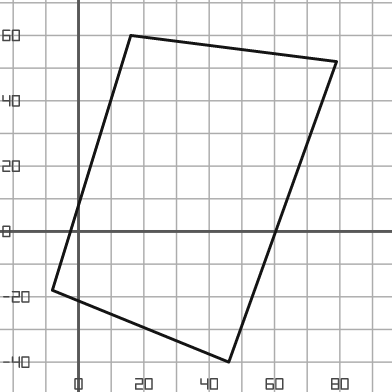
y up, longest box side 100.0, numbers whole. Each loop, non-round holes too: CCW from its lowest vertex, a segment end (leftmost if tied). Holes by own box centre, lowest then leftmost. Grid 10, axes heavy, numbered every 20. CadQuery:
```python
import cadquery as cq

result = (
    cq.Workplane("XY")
    .moveTo(46.0, -40.0)
    .lineTo(79.0, 52.0)
    .lineTo(16.0, 60.0)
    .lineTo(-8.0, -18.0)
    .close()
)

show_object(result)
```